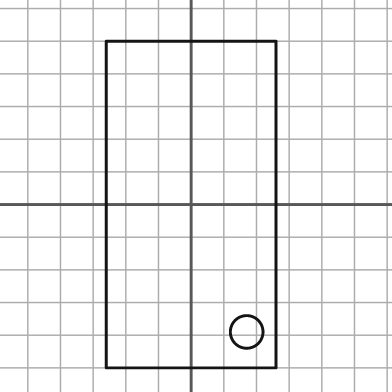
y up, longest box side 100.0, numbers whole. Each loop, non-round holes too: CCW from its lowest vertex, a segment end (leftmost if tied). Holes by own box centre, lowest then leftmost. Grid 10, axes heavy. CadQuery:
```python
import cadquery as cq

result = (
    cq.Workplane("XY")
    .moveTo(-26.0, -50.0)
    .lineTo(26.0, -50.0)
    .lineTo(26.0, 50.0)
    .lineTo(-26.0, 50.0)
    .close()
    .moveTo(17.0, -39.0)
    .circle(5.0)
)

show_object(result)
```